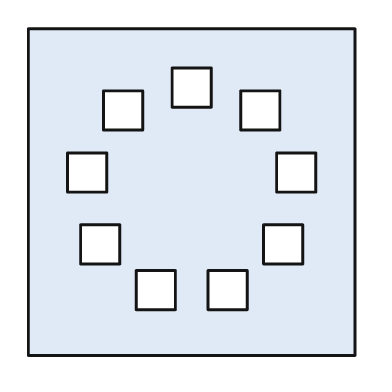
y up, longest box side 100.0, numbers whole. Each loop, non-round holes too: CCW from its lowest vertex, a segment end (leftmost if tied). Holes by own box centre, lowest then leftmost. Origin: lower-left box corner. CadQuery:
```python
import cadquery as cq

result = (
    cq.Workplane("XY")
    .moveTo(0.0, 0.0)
    .lineTo(100.0, 0.0)
    .lineTo(100.0, 100.0)
    .lineTo(0.0, 100.0)
    .close()
    .moveTo(33.0, 14.0)
    .lineTo(45.0, 14.0)
    .lineTo(45.0, 26.0)
    .lineTo(33.0, 26.0)
    .close()
    .moveTo(55.0, 14.0)
    .lineTo(67.0, 14.0)
    .lineTo(67.0, 26.0)
    .lineTo(55.0, 26.0)
    .close()
    .moveTo(16.0, 28.0)
    .lineTo(28.0, 28.0)
    .lineTo(28.0, 40.0)
    .lineTo(16.0, 40.0)
    .close()
    .moveTo(72.0, 28.0)
    .lineTo(84.0, 28.0)
    .lineTo(84.0, 40.0)
    .lineTo(72.0, 40.0)
    .close()
    .moveTo(12.0, 50.0)
    .lineTo(24.0, 50.0)
    .lineTo(24.0, 62.0)
    .lineTo(12.0, 62.0)
    .close()
    .moveTo(76.0, 50.0)
    .lineTo(88.0, 50.0)
    .lineTo(88.0, 62.0)
    .lineTo(76.0, 62.0)
    .close()
    .moveTo(23.0, 69.0)
    .lineTo(35.0, 69.0)
    .lineTo(35.0, 81.0)
    .lineTo(23.0, 81.0)
    .close()
    .moveTo(65.0, 69.0)
    .lineTo(77.0, 69.0)
    .lineTo(77.0, 81.0)
    .lineTo(65.0, 81.0)
    .close()
    .moveTo(44.0, 76.0)
    .lineTo(56.0, 76.0)
    .lineTo(56.0, 88.0)
    .lineTo(44.0, 88.0)
    .close()
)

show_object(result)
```